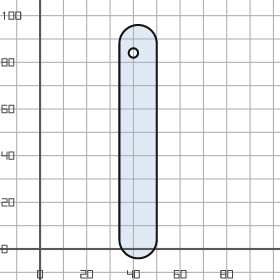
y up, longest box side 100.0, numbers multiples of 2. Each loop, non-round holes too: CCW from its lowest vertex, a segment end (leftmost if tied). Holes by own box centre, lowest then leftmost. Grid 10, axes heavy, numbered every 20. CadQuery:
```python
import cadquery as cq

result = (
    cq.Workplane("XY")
    .moveTo(34.0, 4.0)
    .threePointArc((42.0, -4.0), (50.0, 4.0))
    .lineTo(50.0, 88.0)
    .threePointArc((42.0, 96.0), (34.0, 88.0))
    .close()
    .moveTo(40.0, 84.0)
    .circle(2.0)
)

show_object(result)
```